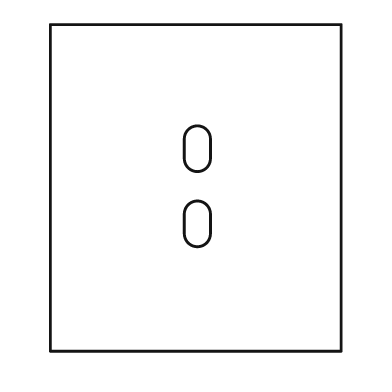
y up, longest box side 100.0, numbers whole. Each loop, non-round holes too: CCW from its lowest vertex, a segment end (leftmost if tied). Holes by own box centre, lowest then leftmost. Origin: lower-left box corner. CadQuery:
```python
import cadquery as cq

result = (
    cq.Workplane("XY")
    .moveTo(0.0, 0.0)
    .lineTo(89.0, 0.0)
    .lineTo(89.0, 100.0)
    .lineTo(0.0, 100.0)
    .close()
    .moveTo(41.0, 36.0)
    .threePointArc((45.0, 32.0), (49.0, 36.0))
    .lineTo(49.0, 42.0)
    .threePointArc((45.0, 46.0), (41.0, 42.0))
    .close()
    .moveTo(41.0, 59.0)
    .threePointArc((45.0, 55.0), (49.0, 59.0))
    .lineTo(49.0, 65.0)
    .threePointArc((45.0, 69.0), (41.0, 65.0))
    .close()
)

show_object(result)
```